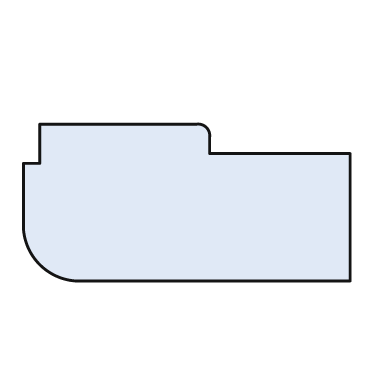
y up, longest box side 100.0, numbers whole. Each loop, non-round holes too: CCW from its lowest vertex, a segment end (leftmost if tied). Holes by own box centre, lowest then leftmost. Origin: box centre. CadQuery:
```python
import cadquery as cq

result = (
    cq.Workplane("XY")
    .moveTo(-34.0, -24.0)
    .lineTo(50.0, -24.0)
    .lineTo(50.0, 15.0)
    .lineTo(7.0, 15.0)
    .lineTo(7.0, 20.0)
    .threePointArc((6.0, 23.0), (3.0, 24.0))
    .lineTo(-45.0, 24.0)
    .lineTo(-45.0, 12.0)
    .lineTo(-50.0, 12.0)
    .lineTo(-50.0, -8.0)
    .threePointArc((-45.0, -19.0), (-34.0, -24.0))
    .close()
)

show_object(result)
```